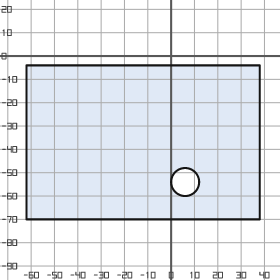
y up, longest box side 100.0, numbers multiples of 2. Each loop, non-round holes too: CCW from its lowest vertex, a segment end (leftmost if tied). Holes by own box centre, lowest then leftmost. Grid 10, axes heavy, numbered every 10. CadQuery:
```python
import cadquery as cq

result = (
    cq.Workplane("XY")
    .moveTo(-62.0, -70.0)
    .lineTo(38.0, -70.0)
    .lineTo(38.0, -4.0)
    .lineTo(-62.0, -4.0)
    .close()
    .moveTo(6.0, -54.0)
    .circle(6.0)
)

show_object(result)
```